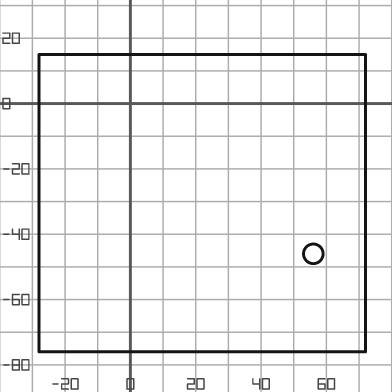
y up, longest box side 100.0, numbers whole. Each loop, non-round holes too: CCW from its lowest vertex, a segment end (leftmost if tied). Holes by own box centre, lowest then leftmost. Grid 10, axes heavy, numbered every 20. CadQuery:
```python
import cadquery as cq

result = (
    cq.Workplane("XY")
    .moveTo(-28.0, -76.0)
    .lineTo(72.0, -76.0)
    .lineTo(72.0, 15.0)
    .lineTo(-28.0, 15.0)
    .close()
    .moveTo(56.0, -46.0)
    .circle(3.0)
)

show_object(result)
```